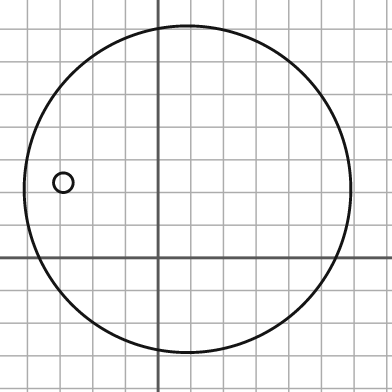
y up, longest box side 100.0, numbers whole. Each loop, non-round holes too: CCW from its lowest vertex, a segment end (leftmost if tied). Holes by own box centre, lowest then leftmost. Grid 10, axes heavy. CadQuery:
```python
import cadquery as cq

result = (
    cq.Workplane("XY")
    .moveTo(9.0, 21.0)
    .circle(50.0)
    .moveTo(-29.0, 23.0)
    .circle(3.0)
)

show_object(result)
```